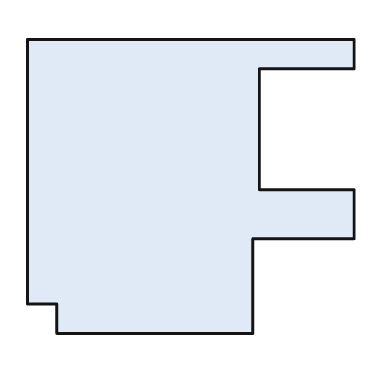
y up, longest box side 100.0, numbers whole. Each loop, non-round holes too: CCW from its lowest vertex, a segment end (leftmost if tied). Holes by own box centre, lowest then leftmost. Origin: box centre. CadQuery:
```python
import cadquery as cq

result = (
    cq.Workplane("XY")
    .moveTo(-41.0, -45.0)
    .lineTo(19.0, -45.0)
    .lineTo(19.0, -16.0)
    .lineTo(50.0, -16.0)
    .lineTo(50.0, -1.0)
    .lineTo(21.0, -1.0)
    .lineTo(21.0, 36.0)
    .lineTo(50.0, 36.0)
    .lineTo(50.0, 45.0)
    .lineTo(-50.0, 45.0)
    .lineTo(-50.0, -36.0)
    .lineTo(-41.0, -36.0)
    .close()
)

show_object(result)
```